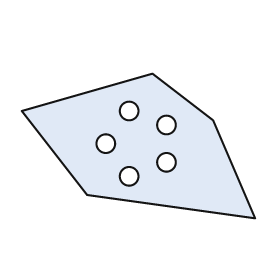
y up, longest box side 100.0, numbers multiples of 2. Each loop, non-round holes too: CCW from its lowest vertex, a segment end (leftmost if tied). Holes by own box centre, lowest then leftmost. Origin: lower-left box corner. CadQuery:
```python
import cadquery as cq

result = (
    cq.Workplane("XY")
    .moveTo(100.0, 0.0)
    .lineTo(82.0, 42.0)
    .lineTo(56.0, 62.0)
    .lineTo(0.0, 46.0)
    .lineTo(28.0, 10.0)
    .close()
    .moveTo(46.0, 18.0)
    .circle(4.0)
    .moveTo(62.0, 24.0)
    .circle(4.0)
    .moveTo(36.0, 32.0)
    .circle(4.0)
    .moveTo(62.0, 40.0)
    .circle(4.0)
    .moveTo(46.0, 46.0)
    .circle(4.0)
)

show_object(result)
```